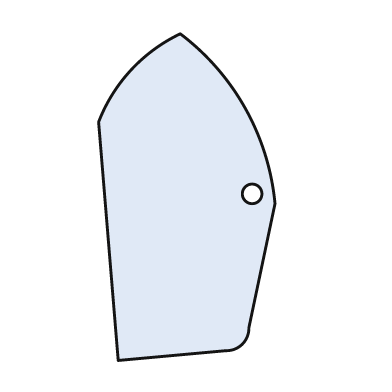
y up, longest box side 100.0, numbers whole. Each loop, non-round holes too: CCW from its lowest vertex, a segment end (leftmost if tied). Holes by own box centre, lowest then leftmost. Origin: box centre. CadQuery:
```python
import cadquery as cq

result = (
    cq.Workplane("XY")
    .moveTo(-21.0, -50.0)
    .lineTo(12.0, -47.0)
    .threePointArc((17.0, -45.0), (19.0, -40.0))
    .lineTo(27.0, -2.0)
    .threePointArc((18.0, 27.0), (-2.0, 50.0))
    .threePointArc((-17.0, 39.0), (-27.0, 23.0))
    .close()
    .moveTo(20.0, 1.0)
    .circle(3.0)
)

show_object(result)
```